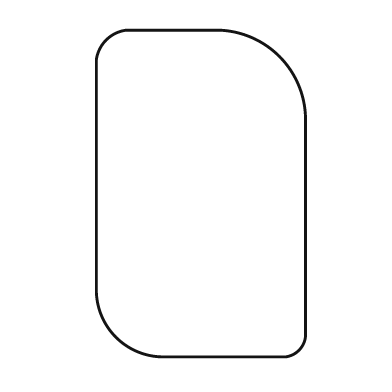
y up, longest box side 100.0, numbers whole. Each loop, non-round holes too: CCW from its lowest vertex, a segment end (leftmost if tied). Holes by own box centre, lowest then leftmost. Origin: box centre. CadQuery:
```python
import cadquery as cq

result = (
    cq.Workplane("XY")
    .moveTo(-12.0, -50.0)
    .lineTo(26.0, -50.0)
    .threePointArc((30.0, -48.0), (32.0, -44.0))
    .lineTo(32.0, 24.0)
    .threePointArc((24.0, 42.0), (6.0, 50.0))
    .lineTo(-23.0, 50.0)
    .threePointArc((-29.0, 47.0), (-32.0, 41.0))
    .lineTo(-32.0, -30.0)
    .threePointArc((-26.0, -44.0), (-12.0, -50.0))
    .close()
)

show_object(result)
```